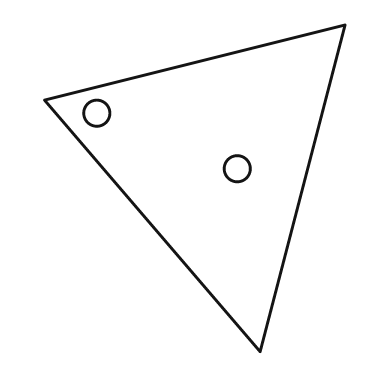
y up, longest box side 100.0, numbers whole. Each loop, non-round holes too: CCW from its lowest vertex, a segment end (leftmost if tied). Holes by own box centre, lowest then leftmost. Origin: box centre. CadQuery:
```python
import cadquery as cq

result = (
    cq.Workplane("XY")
    .moveTo(20.0, -50.0)
    .lineTo(46.0, 50.0)
    .lineTo(-46.0, 27.0)
    .close()
    .moveTo(13.0, 6.0)
    .circle(4.0)
    .moveTo(-30.0, 23.0)
    .circle(4.0)
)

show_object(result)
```